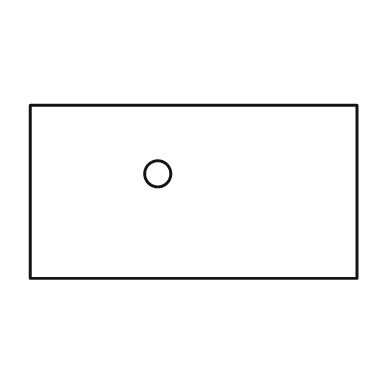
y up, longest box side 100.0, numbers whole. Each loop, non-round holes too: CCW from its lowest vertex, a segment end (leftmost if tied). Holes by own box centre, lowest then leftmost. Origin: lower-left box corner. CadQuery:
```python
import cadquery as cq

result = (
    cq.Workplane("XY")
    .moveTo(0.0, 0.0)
    .lineTo(100.0, 0.0)
    .lineTo(100.0, 53.0)
    .lineTo(0.0, 53.0)
    .close()
    .moveTo(39.0, 32.0)
    .circle(4.0)
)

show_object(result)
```